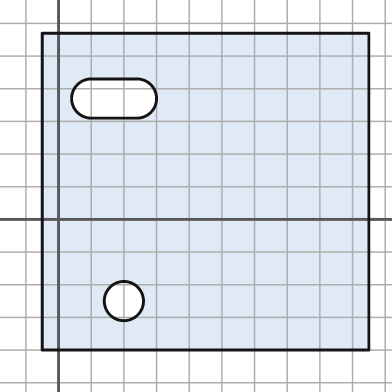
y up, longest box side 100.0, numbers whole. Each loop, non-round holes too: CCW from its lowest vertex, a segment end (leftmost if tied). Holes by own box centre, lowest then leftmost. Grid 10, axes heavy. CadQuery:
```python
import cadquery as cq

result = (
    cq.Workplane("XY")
    .moveTo(-5.0, -40.0)
    .lineTo(95.0, -40.0)
    .lineTo(95.0, 57.0)
    .lineTo(-5.0, 57.0)
    .close()
    .moveTo(20.0, -25.0)
    .circle(6.0)
    .moveTo(10.0, 31.0)
    .lineTo(24.0, 31.0)
    .threePointArc((30.0, 37.0), (24.0, 43.0))
    .lineTo(10.0, 43.0)
    .threePointArc((4.0, 37.0), (10.0, 31.0))
    .close()
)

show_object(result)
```